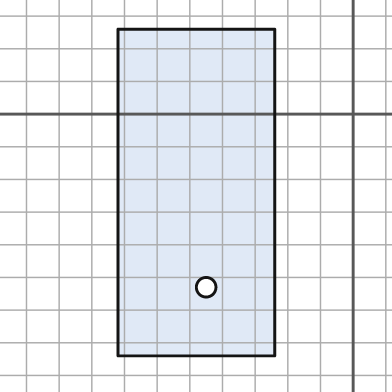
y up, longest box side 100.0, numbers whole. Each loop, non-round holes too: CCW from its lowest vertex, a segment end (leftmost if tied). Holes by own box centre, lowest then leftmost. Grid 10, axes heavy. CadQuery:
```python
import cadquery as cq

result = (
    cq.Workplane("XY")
    .moveTo(-72.0, -74.0)
    .lineTo(-24.0, -74.0)
    .lineTo(-24.0, 26.0)
    .lineTo(-72.0, 26.0)
    .close()
    .moveTo(-45.0, -53.0)
    .circle(3.0)
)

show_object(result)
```